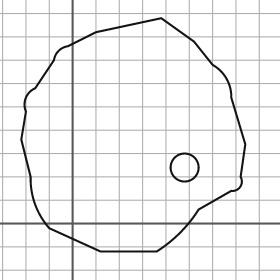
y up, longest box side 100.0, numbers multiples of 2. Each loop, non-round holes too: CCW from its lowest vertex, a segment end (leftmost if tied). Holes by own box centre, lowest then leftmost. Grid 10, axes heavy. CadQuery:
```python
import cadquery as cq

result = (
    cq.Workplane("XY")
    .moveTo(12.0, -12.0)
    .lineTo(36.0, -12.0)
    .threePointArc((46.0, -4.0), (54.0, 6.0))
    .lineTo(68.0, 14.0)
    .threePointArc((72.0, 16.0), (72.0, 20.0))
    .lineTo(74.0, 34.0)
    .lineTo(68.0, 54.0)
    .threePointArc((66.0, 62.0), (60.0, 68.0))
    .lineTo(52.0, 78.0)
    .lineTo(38.0, 88.0)
    .lineTo(10.0, 82.0)
    .lineTo(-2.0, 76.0)
    .threePointArc((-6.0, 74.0), (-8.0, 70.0))
    .lineTo(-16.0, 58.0)
    .threePointArc((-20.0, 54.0), (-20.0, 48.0))
    .lineTo(-22.0, 36.0)
    .lineTo(-18.0, 20.0)
    .threePointArc((-16.0, 8.0), (-10.0, -2.0))
    .close()
    .moveTo(48.0, 24.0)
    .circle(6.0)
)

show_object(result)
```